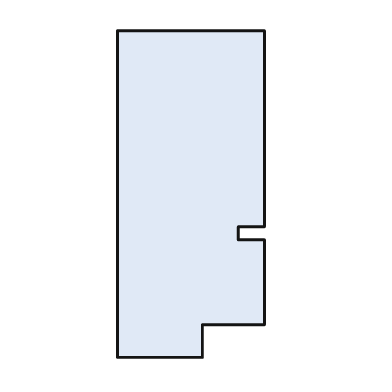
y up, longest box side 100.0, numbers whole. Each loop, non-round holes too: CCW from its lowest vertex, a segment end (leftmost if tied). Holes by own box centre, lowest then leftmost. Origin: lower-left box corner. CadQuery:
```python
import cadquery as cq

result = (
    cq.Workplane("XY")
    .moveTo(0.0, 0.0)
    .lineTo(26.0, 0.0)
    .lineTo(26.0, 10.0)
    .lineTo(45.0, 10.0)
    .lineTo(45.0, 36.0)
    .lineTo(37.0, 36.0)
    .lineTo(37.0, 40.0)
    .lineTo(45.0, 40.0)
    .lineTo(45.0, 100.0)
    .lineTo(0.0, 100.0)
    .close()
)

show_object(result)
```